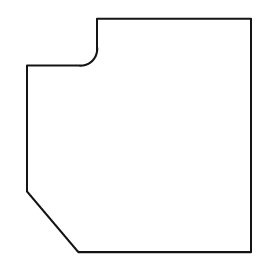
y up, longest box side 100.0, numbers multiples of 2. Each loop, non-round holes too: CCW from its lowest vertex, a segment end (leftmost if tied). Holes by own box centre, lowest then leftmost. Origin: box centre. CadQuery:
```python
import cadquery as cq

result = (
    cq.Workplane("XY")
    .moveTo(-26.0, -50.0)
    .lineTo(48.0, -50.0)
    .lineTo(48.0, 50.0)
    .lineTo(-18.0, 50.0)
    .lineTo(-18.0, 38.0)
    .threePointArc((-20.0, 32.0), (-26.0, 30.0))
    .lineTo(-48.0, 30.0)
    .lineTo(-48.0, -24.0)
    .close()
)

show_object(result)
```